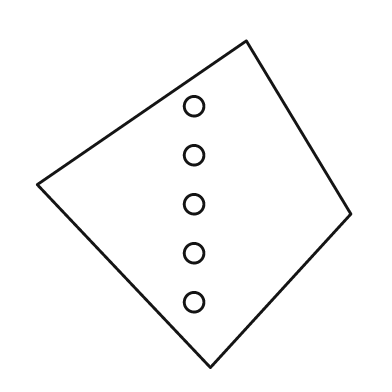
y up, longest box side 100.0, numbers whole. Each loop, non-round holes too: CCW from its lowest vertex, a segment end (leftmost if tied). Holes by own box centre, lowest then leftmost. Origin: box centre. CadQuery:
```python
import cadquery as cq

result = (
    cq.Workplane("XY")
    .moveTo(5.0, -50.0)
    .lineTo(48.0, -3.0)
    .lineTo(16.0, 50.0)
    .lineTo(-48.0, 6.0)
    .close()
    .moveTo(0.0, -30.0)
    .circle(3.0)
    .moveTo(0.0, -15.0)
    .circle(3.0)
    .moveTo(0.0, 0.0)
    .circle(3.0)
    .moveTo(0.0, 15.0)
    .circle(3.0)
    .moveTo(0.0, 30.0)
    .circle(3.0)
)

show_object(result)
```